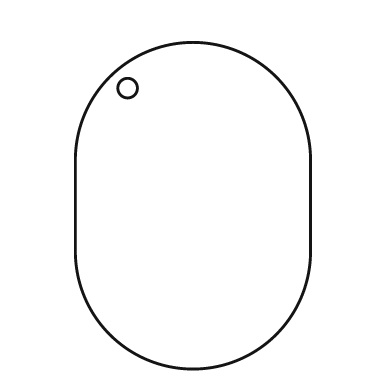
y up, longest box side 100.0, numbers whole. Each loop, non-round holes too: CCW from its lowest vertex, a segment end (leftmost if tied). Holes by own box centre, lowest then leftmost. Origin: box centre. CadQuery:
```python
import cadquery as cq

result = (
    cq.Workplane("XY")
    .moveTo(-36.0, -14.0)
    .threePointArc((0.0, -50.0), (36.0, -14.0))
    .lineTo(36.0, 14.0)
    .threePointArc((0.0, 50.0), (-36.0, 14.0))
    .close()
    .moveTo(-20.0, 36.0)
    .circle(3.0)
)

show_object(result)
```